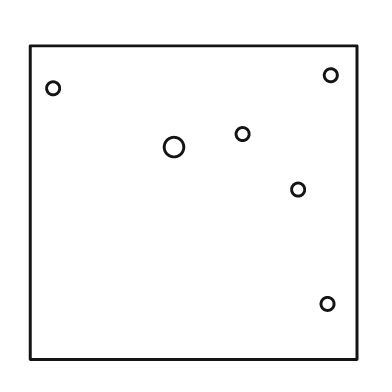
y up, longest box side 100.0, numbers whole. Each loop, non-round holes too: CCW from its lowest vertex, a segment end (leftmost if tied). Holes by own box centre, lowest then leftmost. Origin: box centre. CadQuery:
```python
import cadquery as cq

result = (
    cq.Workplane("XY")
    .moveTo(-50.0, -48.0)
    .lineTo(50.0, -48.0)
    .lineTo(50.0, 48.0)
    .lineTo(-50.0, 48.0)
    .close()
    .moveTo(41.0, -31.0)
    .circle(2.0)
    .moveTo(32.0, 4.0)
    .circle(2.0)
    .moveTo(-6.0, 17.0)
    .circle(3.0)
    .moveTo(15.0, 21.0)
    .circle(2.0)
    .moveTo(-43.0, 35.0)
    .circle(2.0)
    .moveTo(42.0, 39.0)
    .circle(2.0)
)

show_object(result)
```